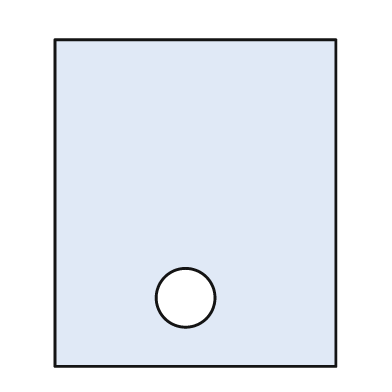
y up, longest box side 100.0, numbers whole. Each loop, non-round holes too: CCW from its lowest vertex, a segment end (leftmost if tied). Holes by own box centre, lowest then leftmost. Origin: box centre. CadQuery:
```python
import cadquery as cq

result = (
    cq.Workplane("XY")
    .moveTo(-43.0, -50.0)
    .lineTo(43.0, -50.0)
    .lineTo(43.0, 50.0)
    .lineTo(-43.0, 50.0)
    .close()
    .moveTo(-3.0, -29.0)
    .circle(9.0)
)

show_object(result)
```